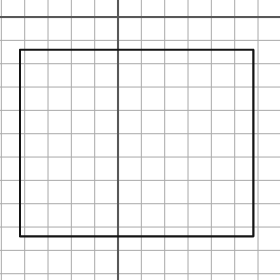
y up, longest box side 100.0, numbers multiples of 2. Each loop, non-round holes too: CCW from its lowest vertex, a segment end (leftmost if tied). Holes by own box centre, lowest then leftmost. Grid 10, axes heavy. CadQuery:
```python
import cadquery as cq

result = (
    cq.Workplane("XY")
    .moveTo(-42.0, -94.0)
    .lineTo(58.0, -94.0)
    .lineTo(58.0, -14.0)
    .lineTo(-42.0, -14.0)
    .close()
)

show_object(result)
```